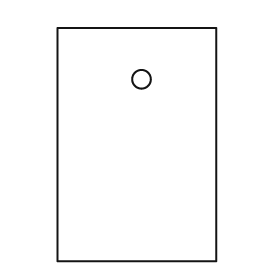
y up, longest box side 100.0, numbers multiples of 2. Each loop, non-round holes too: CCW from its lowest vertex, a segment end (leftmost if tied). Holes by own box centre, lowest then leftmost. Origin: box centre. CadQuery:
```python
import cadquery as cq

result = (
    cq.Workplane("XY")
    .moveTo(-34.0, -50.0)
    .lineTo(34.0, -50.0)
    .lineTo(34.0, 50.0)
    .lineTo(-34.0, 50.0)
    .close()
    .moveTo(2.0, 28.0)
    .circle(4.0)
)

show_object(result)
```